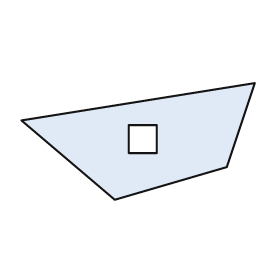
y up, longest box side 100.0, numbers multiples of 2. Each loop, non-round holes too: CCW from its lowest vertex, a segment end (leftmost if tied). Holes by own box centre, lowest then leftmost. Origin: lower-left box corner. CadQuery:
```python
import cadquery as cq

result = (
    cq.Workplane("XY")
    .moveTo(40.0, 0.0)
    .lineTo(88.0, 14.0)
    .lineTo(100.0, 50.0)
    .lineTo(0.0, 34.0)
    .close()
    .moveTo(46.0, 20.0)
    .lineTo(58.0, 20.0)
    .lineTo(58.0, 32.0)
    .lineTo(46.0, 32.0)
    .close()
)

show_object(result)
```